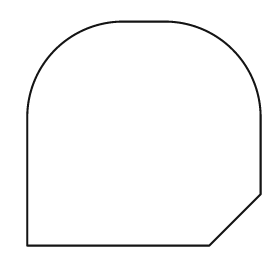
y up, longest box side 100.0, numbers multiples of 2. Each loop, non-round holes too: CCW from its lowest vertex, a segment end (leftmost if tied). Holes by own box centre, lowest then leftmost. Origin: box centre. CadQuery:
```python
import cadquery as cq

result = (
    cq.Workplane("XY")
    .moveTo(-50.0, -48.0)
    .lineTo(28.0, -48.0)
    .lineTo(50.0, -26.0)
    .lineTo(50.0, 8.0)
    .threePointArc((38.0, 36.0), (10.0, 48.0))
    .lineTo(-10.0, 48.0)
    .threePointArc((-38.0, 36.0), (-50.0, 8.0))
    .close()
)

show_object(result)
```